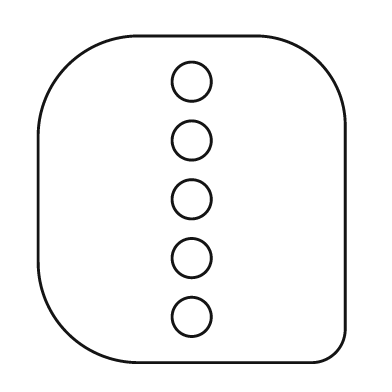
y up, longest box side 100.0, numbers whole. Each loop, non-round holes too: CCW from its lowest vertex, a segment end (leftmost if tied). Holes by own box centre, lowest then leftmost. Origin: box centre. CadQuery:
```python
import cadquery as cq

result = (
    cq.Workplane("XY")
    .moveTo(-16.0, -50.0)
    .lineTo(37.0, -50.0)
    .threePointArc((44.0, -47.0), (47.0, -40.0))
    .lineTo(47.0, 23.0)
    .threePointArc((39.0, 42.0), (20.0, 50.0))
    .lineTo(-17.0, 50.0)
    .threePointArc((-38.0, 41.0), (-47.0, 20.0))
    .lineTo(-47.0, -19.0)
    .threePointArc((-38.0, -41.0), (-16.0, -50.0))
    .close()
    .moveTo(0.0, -36.0)
    .circle(6.0)
    .moveTo(0.0, -18.0)
    .circle(6.0)
    .moveTo(0.0, 0.0)
    .circle(6.0)
    .moveTo(0.0, 18.0)
    .circle(6.0)
    .moveTo(0.0, 36.0)
    .circle(6.0)
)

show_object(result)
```